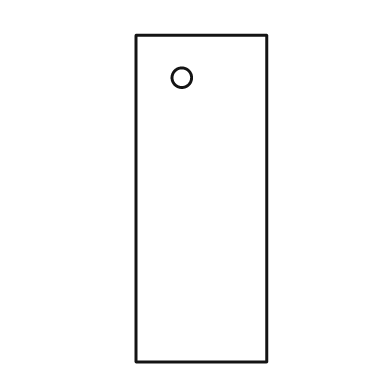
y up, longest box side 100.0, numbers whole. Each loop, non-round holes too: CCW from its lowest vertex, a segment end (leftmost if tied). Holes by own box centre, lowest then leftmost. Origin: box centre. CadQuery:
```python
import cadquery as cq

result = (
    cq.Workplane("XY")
    .moveTo(-20.0, -50.0)
    .lineTo(20.0, -50.0)
    .lineTo(20.0, 50.0)
    .lineTo(-20.0, 50.0)
    .close()
    .moveTo(-6.0, 37.0)
    .circle(3.0)
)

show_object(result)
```